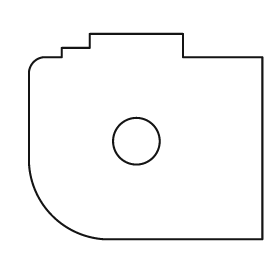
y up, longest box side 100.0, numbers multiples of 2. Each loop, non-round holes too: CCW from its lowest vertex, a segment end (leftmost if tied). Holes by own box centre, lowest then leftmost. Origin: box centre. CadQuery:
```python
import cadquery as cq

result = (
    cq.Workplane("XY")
    .moveTo(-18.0, -44.0)
    .lineTo(50.0, -44.0)
    .lineTo(50.0, 34.0)
    .lineTo(16.0, 34.0)
    .lineTo(16.0, 44.0)
    .lineTo(-24.0, 44.0)
    .lineTo(-24.0, 38.0)
    .lineTo(-36.0, 38.0)
    .lineTo(-36.0, 34.0)
    .lineTo(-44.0, 34.0)
    .threePointArc((-48.0, 32.0), (-50.0, 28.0))
    .lineTo(-50.0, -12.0)
    .threePointArc((-40.0, -34.0), (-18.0, -44.0))
    .close()
    .moveTo(-4.0, -2.0)
    .circle(10.0)
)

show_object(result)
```